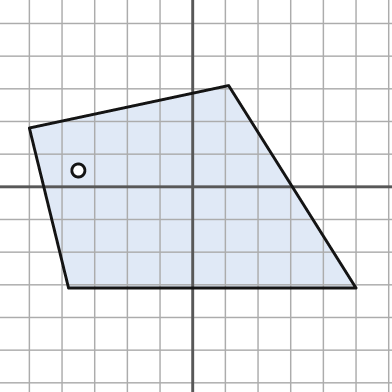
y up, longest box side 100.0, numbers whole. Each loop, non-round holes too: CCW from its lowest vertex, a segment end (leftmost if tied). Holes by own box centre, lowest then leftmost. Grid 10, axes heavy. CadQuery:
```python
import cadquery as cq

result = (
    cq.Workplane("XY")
    .moveTo(-38.0, -31.0)
    .lineTo(50.0, -31.0)
    .lineTo(11.0, 31.0)
    .lineTo(-50.0, 18.0)
    .close()
    .moveTo(-35.0, 5.0)
    .circle(2.0)
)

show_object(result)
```